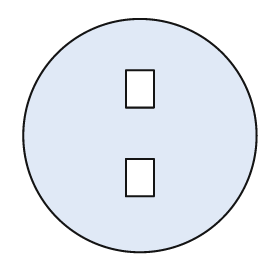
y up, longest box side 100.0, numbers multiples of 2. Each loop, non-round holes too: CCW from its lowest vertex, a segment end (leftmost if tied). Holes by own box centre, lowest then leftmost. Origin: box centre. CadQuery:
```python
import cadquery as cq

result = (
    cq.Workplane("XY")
    .moveTo(0.0, 0.0)
    .circle(50.0)
    .moveTo(-6.0, -26.0)
    .lineTo(6.0, -26.0)
    .lineTo(6.0, -10.0)
    .lineTo(-6.0, -10.0)
    .close()
    .moveTo(-6.0, 12.0)
    .lineTo(6.0, 12.0)
    .lineTo(6.0, 28.0)
    .lineTo(-6.0, 28.0)
    .close()
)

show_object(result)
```